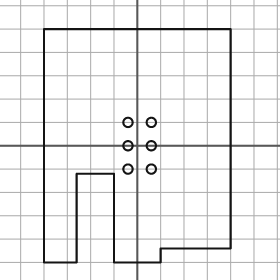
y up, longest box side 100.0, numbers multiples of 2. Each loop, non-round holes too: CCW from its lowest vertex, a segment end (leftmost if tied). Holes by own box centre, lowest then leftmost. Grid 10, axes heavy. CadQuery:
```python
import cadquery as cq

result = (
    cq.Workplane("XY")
    .moveTo(-40.0, -50.0)
    .lineTo(-26.0, -50.0)
    .lineTo(-26.0, -12.0)
    .lineTo(-10.0, -12.0)
    .lineTo(-10.0, -50.0)
    .lineTo(10.0, -50.0)
    .lineTo(10.0, -44.0)
    .lineTo(40.0, -44.0)
    .lineTo(40.0, 50.0)
    .lineTo(-40.0, 50.0)
    .close()
    .moveTo(-4.0, -10.0)
    .circle(2.0)
    .moveTo(6.0, -10.0)
    .circle(2.0)
    .moveTo(-4.0, 0.0)
    .circle(2.0)
    .moveTo(6.0, 0.0)
    .circle(2.0)
    .moveTo(-4.0, 10.0)
    .circle(2.0)
    .moveTo(6.0, 10.0)
    .circle(2.0)
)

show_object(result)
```